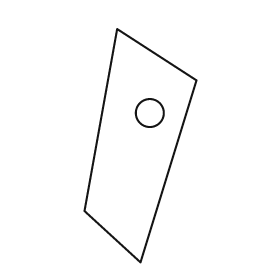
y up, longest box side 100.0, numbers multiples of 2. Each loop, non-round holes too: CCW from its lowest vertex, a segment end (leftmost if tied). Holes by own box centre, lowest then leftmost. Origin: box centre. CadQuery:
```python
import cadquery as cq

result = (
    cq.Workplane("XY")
    .moveTo(0.0, -50.0)
    .lineTo(24.0, 28.0)
    .lineTo(-10.0, 50.0)
    .lineTo(-24.0, -28.0)
    .close()
    .moveTo(4.0, 14.0)
    .circle(6.0)
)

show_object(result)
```